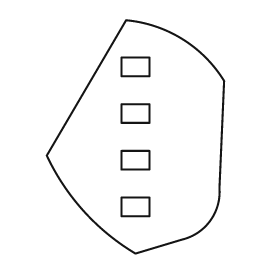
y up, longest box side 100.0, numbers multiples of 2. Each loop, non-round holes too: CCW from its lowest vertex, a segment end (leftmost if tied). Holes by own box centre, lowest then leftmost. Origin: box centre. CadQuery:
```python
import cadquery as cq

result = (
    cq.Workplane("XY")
    .moveTo(0.0, -50.0)
    .lineTo(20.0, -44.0)
    .threePointArc((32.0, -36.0), (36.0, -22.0))
    .lineTo(38.0, 24.0)
    .threePointArc((20.0, 42.0), (-4.0, 50.0))
    .lineTo(-38.0, -8.0)
    .threePointArc((-22.0, -32.0), (0.0, -50.0))
    .close()
    .moveTo(-6.0, -34.0)
    .lineTo(6.0, -34.0)
    .lineTo(6.0, -26.0)
    .lineTo(-6.0, -26.0)
    .close()
    .moveTo(-6.0, -14.0)
    .lineTo(6.0, -14.0)
    .lineTo(6.0, -6.0)
    .lineTo(-6.0, -6.0)
    .close()
    .moveTo(-6.0, 6.0)
    .lineTo(6.0, 6.0)
    .lineTo(6.0, 14.0)
    .lineTo(-6.0, 14.0)
    .close()
    .moveTo(-6.0, 26.0)
    .lineTo(6.0, 26.0)
    .lineTo(6.0, 34.0)
    .lineTo(-6.0, 34.0)
    .close()
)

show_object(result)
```